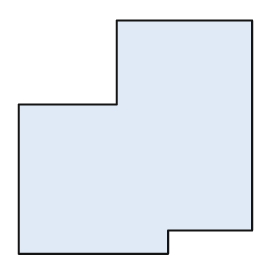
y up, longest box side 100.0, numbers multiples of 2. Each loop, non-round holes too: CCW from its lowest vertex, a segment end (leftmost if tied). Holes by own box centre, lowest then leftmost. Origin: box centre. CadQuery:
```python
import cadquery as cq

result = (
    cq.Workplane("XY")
    .moveTo(-50.0, -50.0)
    .lineTo(14.0, -50.0)
    .lineTo(14.0, -40.0)
    .lineTo(50.0, -40.0)
    .lineTo(50.0, 50.0)
    .lineTo(-8.0, 50.0)
    .lineTo(-8.0, 14.0)
    .lineTo(-50.0, 14.0)
    .close()
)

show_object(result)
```